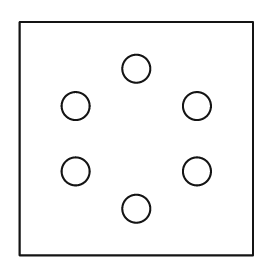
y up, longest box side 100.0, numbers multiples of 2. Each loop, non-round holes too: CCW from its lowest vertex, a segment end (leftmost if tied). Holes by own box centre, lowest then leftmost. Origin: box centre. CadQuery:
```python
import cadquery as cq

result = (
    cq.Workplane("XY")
    .moveTo(-50.0, -50.0)
    .lineTo(50.0, -50.0)
    .lineTo(50.0, 50.0)
    .lineTo(-50.0, 50.0)
    .close()
    .moveTo(0.0, -30.0)
    .circle(6.0)
    .moveTo(-26.0, -14.0)
    .circle(6.0)
    .moveTo(26.0, -14.0)
    .circle(6.0)
    .moveTo(-26.0, 14.0)
    .circle(6.0)
    .moveTo(26.0, 14.0)
    .circle(6.0)
    .moveTo(0.0, 30.0)
    .circle(6.0)
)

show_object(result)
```